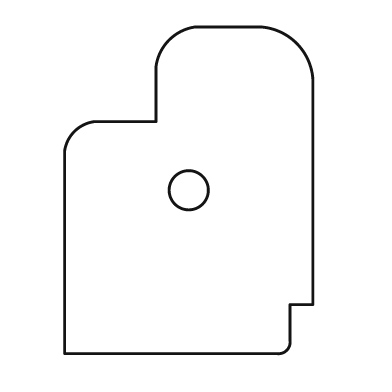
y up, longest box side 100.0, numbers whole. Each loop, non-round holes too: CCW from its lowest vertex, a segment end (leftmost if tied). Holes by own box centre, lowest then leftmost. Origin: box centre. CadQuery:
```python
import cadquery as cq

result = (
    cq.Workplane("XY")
    .moveTo(-38.0, -50.0)
    .lineTo(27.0, -50.0)
    .threePointArc((30.0, -49.0), (31.0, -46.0))
    .lineTo(31.0, -35.0)
    .lineTo(38.0, -35.0)
    .lineTo(38.0, 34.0)
    .threePointArc((33.0, 45.0), (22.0, 50.0))
    .lineTo(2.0, 50.0)
    .threePointArc((-6.0, 46.0), (-10.0, 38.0))
    .lineTo(-10.0, 21.0)
    .lineTo(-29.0, 21.0)
    .threePointArc((-35.0, 18.0), (-38.0, 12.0))
    .close()
    .moveTo(0.0, 0.0)
    .circle(6.0)
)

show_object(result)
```